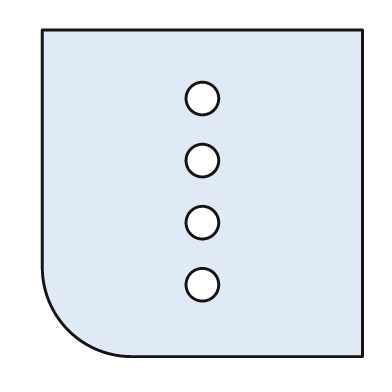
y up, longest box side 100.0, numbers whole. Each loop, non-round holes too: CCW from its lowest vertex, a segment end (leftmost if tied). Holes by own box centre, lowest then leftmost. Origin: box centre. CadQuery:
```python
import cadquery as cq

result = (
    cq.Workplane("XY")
    .moveTo(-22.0, -50.0)
    .lineTo(49.0, -50.0)
    .lineTo(49.0, 50.0)
    .lineTo(-49.0, 50.0)
    .lineTo(-49.0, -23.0)
    .threePointArc((-41.0, -42.0), (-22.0, -50.0))
    .close()
    .moveTo(0.0, -28.0)
    .circle(5.0)
    .moveTo(0.0, -9.0)
    .circle(5.0)
    .moveTo(0.0, 10.0)
    .circle(5.0)
    .moveTo(0.0, 29.0)
    .circle(5.0)
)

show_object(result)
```